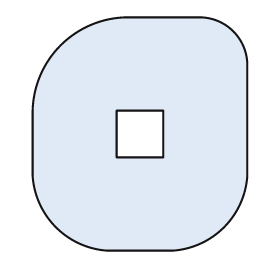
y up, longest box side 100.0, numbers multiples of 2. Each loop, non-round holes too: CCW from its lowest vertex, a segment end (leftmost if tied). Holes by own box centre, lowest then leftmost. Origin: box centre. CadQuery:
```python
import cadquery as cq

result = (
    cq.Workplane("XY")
    .moveTo(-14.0, -50.0)
    .lineTo(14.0, -50.0)
    .threePointArc((36.0, -40.0), (46.0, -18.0))
    .lineTo(46.0, 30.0)
    .threePointArc((40.0, 44.0), (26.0, 50.0))
    .lineTo(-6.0, 50.0)
    .threePointArc((-34.0, 38.0), (-46.0, 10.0))
    .lineTo(-46.0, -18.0)
    .threePointArc((-36.0, -40.0), (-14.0, -50.0))
    .close()
    .moveTo(-10.0, -10.0)
    .lineTo(10.0, -10.0)
    .lineTo(10.0, 10.0)
    .lineTo(-10.0, 10.0)
    .close()
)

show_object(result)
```